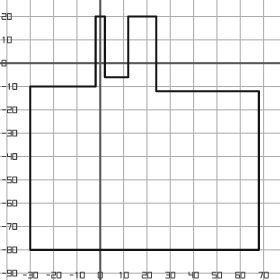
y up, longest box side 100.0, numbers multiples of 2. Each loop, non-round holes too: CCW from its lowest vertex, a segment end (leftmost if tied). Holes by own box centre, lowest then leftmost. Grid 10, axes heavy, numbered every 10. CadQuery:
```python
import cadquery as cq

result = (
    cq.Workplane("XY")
    .moveTo(-30.0, -80.0)
    .lineTo(68.0, -80.0)
    .lineTo(68.0, -12.0)
    .lineTo(24.0, -12.0)
    .lineTo(24.0, 20.0)
    .lineTo(12.0, 20.0)
    .lineTo(12.0, -6.0)
    .lineTo(2.0, -6.0)
    .lineTo(2.0, 20.0)
    .lineTo(-2.0, 20.0)
    .lineTo(-2.0, -10.0)
    .lineTo(-30.0, -10.0)
    .close()
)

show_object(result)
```